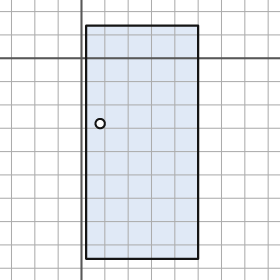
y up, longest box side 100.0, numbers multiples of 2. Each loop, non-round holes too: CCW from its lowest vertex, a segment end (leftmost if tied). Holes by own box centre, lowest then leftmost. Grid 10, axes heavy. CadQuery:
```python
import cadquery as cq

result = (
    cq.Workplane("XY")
    .moveTo(2.0, -86.0)
    .lineTo(50.0, -86.0)
    .lineTo(50.0, 14.0)
    .lineTo(2.0, 14.0)
    .close()
    .moveTo(8.0, -28.0)
    .circle(2.0)
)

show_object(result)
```